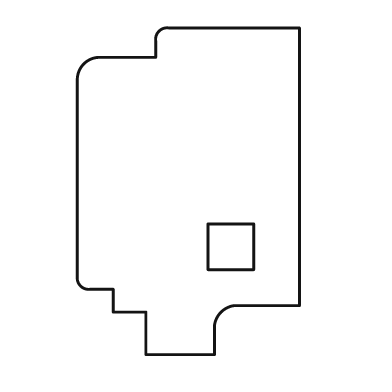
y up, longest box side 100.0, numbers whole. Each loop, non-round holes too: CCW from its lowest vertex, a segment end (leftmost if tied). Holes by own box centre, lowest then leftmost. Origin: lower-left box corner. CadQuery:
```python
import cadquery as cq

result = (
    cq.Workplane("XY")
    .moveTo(21.0, 0.0)
    .lineTo(42.0, 0.0)
    .lineTo(42.0, 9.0)
    .threePointArc((44.0, 13.0), (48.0, 15.0))
    .lineTo(68.0, 15.0)
    .lineTo(68.0, 100.0)
    .lineTo(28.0, 100.0)
    .threePointArc((25.0, 99.0), (24.0, 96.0))
    .lineTo(24.0, 91.0)
    .lineTo(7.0, 91.0)
    .threePointArc((2.0, 89.0), (0.0, 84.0))
    .lineTo(0.0, 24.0)
    .threePointArc((1.0, 21.0), (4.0, 20.0))
    .lineTo(11.0, 20.0)
    .lineTo(11.0, 13.0)
    .lineTo(21.0, 13.0)
    .close()
    .moveTo(40.0, 26.0)
    .lineTo(54.0, 26.0)
    .lineTo(54.0, 40.0)
    .lineTo(40.0, 40.0)
    .close()
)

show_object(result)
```